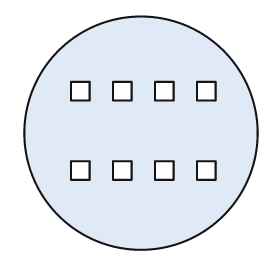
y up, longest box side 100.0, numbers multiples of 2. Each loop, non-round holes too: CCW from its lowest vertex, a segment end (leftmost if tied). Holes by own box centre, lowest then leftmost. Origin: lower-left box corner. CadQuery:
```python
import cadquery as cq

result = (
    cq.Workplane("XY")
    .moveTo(50.0, 50.0)
    .circle(50.0)
    .moveTo(20.0, 30.0)
    .lineTo(28.0, 30.0)
    .lineTo(28.0, 38.0)
    .lineTo(20.0, 38.0)
    .close()
    .moveTo(38.0, 30.0)
    .lineTo(46.0, 30.0)
    .lineTo(46.0, 38.0)
    .lineTo(38.0, 38.0)
    .close()
    .moveTo(56.0, 30.0)
    .lineTo(64.0, 30.0)
    .lineTo(64.0, 38.0)
    .lineTo(56.0, 38.0)
    .close()
    .moveTo(74.0, 30.0)
    .lineTo(82.0, 30.0)
    .lineTo(82.0, 38.0)
    .lineTo(74.0, 38.0)
    .close()
    .moveTo(20.0, 64.0)
    .lineTo(28.0, 64.0)
    .lineTo(28.0, 72.0)
    .lineTo(20.0, 72.0)
    .close()
    .moveTo(38.0, 64.0)
    .lineTo(46.0, 64.0)
    .lineTo(46.0, 72.0)
    .lineTo(38.0, 72.0)
    .close()
    .moveTo(56.0, 64.0)
    .lineTo(64.0, 64.0)
    .lineTo(64.0, 72.0)
    .lineTo(56.0, 72.0)
    .close()
    .moveTo(74.0, 64.0)
    .lineTo(82.0, 64.0)
    .lineTo(82.0, 72.0)
    .lineTo(74.0, 72.0)
    .close()
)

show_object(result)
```